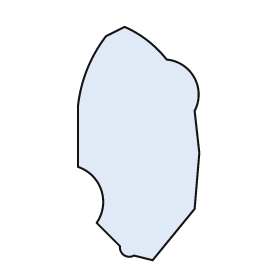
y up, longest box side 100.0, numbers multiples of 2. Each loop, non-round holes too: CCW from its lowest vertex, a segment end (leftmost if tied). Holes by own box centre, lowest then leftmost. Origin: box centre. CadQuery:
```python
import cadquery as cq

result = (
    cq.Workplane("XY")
    .moveTo(6.0, -50.0)
    .lineTo(24.0, -28.0)
    .lineTo(26.0, -4.0)
    .lineTo(24.0, 14.0)
    .threePointArc((24.0, 28.0), (12.0, 36.0))
    .threePointArc((4.0, 44.0), (-6.0, 50.0))
    .lineTo(-14.0, 46.0)
    .threePointArc((-22.0, 32.0), (-26.0, 16.0))
    .lineTo(-26.0, -10.0)
    .threePointArc((-16.0, -20.0), (-18.0, -34.0))
    .lineTo(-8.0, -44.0)
    .threePointArc((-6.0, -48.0), (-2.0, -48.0))
    .close()
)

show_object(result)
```